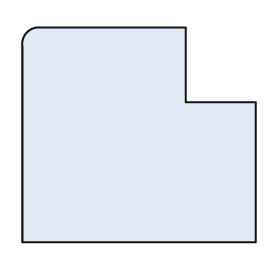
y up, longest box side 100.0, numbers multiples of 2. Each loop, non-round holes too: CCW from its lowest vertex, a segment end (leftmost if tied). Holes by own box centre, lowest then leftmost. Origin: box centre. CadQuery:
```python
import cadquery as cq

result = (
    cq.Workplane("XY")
    .moveTo(-50.0, -46.0)
    .lineTo(50.0, -46.0)
    .lineTo(50.0, 14.0)
    .lineTo(20.0, 14.0)
    .lineTo(20.0, 46.0)
    .lineTo(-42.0, 46.0)
    .threePointArc((-48.0, 44.0), (-50.0, 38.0))
    .close()
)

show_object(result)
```